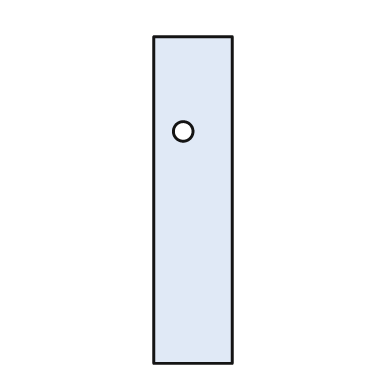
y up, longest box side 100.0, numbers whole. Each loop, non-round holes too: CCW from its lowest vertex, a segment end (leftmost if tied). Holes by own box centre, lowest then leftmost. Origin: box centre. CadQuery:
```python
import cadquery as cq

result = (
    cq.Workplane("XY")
    .moveTo(-12.0, -50.0)
    .lineTo(12.0, -50.0)
    .lineTo(12.0, 50.0)
    .lineTo(-12.0, 50.0)
    .close()
    .moveTo(-3.0, 21.0)
    .circle(3.0)
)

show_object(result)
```